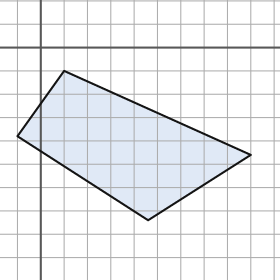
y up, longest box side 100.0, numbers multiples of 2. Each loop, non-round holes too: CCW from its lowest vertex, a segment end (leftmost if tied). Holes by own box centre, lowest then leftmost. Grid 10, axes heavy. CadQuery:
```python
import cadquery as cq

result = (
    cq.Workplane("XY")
    .moveTo(46.0, -74.0)
    .lineTo(90.0, -46.0)
    .lineTo(10.0, -10.0)
    .lineTo(-10.0, -38.0)
    .close()
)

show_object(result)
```